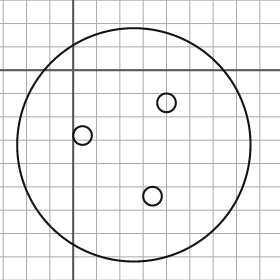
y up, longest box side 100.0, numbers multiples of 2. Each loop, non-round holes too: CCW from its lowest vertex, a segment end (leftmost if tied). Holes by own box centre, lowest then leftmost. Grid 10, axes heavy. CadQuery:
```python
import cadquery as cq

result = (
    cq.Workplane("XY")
    .moveTo(26.0, -32.0)
    .circle(50.0)
    .moveTo(34.0, -54.0)
    .circle(4.0)
    .moveTo(4.0, -28.0)
    .circle(4.0)
    .moveTo(40.0, -14.0)
    .circle(4.0)
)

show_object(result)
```